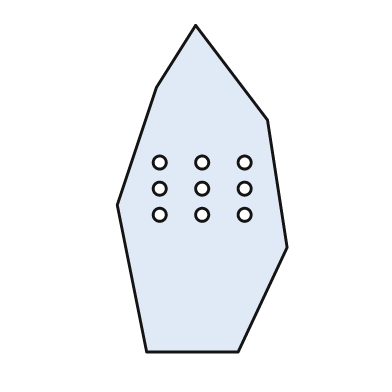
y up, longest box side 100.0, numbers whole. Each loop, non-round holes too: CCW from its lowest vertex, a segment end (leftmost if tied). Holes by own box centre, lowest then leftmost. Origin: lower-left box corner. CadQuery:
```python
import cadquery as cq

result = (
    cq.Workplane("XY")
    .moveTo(9.0, 0.0)
    .lineTo(37.0, 0.0)
    .lineTo(52.0, 32.0)
    .lineTo(46.0, 71.0)
    .lineTo(24.0, 100.0)
    .lineTo(12.0, 81.0)
    .lineTo(0.0, 45.0)
    .close()
    .moveTo(13.0, 42.0)
    .circle(2.0)
    .moveTo(26.0, 42.0)
    .circle(2.0)
    .moveTo(39.0, 42.0)
    .circle(2.0)
    .moveTo(13.0, 50.0)
    .circle(2.0)
    .moveTo(26.0, 50.0)
    .circle(2.0)
    .moveTo(39.0, 50.0)
    .circle(2.0)
    .moveTo(13.0, 58.0)
    .circle(2.0)
    .moveTo(26.0, 58.0)
    .circle(2.0)
    .moveTo(39.0, 58.0)
    .circle(2.0)
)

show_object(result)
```